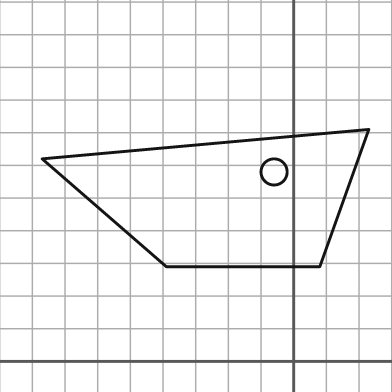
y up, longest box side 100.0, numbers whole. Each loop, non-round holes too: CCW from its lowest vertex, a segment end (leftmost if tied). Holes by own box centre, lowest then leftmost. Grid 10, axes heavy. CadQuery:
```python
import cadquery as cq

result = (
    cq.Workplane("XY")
    .moveTo(-39.0, 29.0)
    .lineTo(8.0, 29.0)
    .lineTo(23.0, 71.0)
    .lineTo(-77.0, 62.0)
    .close()
    .moveTo(-6.0, 58.0)
    .circle(4.0)
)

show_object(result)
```